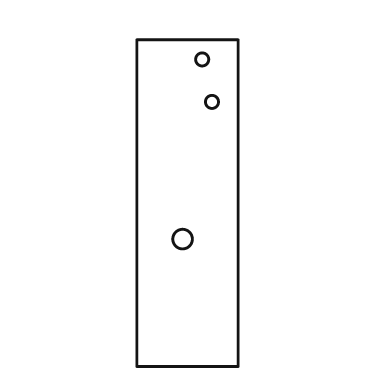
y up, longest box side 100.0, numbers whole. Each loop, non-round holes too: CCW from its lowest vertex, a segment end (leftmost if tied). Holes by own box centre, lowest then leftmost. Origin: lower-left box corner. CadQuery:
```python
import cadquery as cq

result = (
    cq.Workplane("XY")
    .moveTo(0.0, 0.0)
    .lineTo(31.0, 0.0)
    .lineTo(31.0, 100.0)
    .lineTo(0.0, 100.0)
    .close()
    .moveTo(14.0, 39.0)
    .circle(3.0)
    .moveTo(23.0, 81.0)
    .circle(2.0)
    .moveTo(20.0, 94.0)
    .circle(2.0)
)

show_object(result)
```